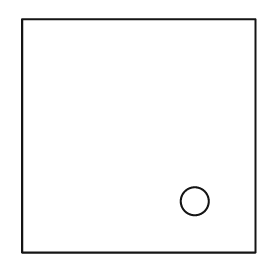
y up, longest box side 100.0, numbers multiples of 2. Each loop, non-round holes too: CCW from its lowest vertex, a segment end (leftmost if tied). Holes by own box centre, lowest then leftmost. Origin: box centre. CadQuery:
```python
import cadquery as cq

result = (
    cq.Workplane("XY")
    .moveTo(-50.0, -50.0)
    .lineTo(50.0, -50.0)
    .lineTo(50.0, 50.0)
    .lineTo(-50.0, 50.0)
    .close()
    .moveTo(24.0, -28.0)
    .circle(6.0)
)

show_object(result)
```